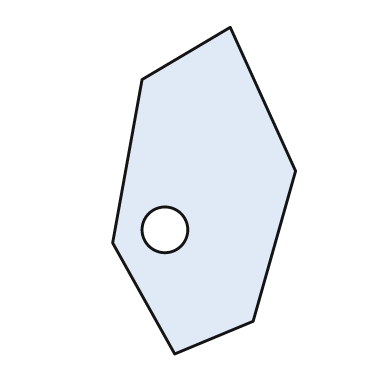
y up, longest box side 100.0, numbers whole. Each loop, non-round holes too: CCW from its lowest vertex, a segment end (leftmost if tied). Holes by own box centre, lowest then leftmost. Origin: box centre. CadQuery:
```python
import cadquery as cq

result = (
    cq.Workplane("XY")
    .moveTo(-9.0, -50.0)
    .lineTo(15.0, -40.0)
    .lineTo(28.0, 6.0)
    .lineTo(8.0, 50.0)
    .lineTo(-19.0, 34.0)
    .lineTo(-28.0, -16.0)
    .close()
    .moveTo(-12.0, -12.0)
    .circle(7.0)
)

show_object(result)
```